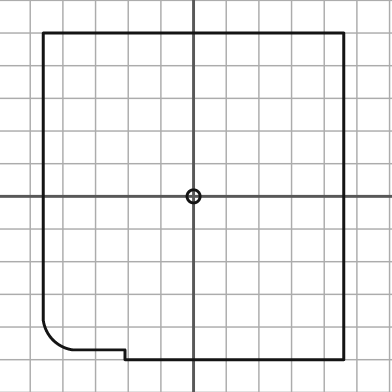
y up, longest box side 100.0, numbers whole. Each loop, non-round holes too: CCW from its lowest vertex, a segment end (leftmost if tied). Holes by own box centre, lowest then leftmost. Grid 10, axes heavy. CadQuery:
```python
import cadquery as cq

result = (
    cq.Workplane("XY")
    .moveTo(-21.0, -50.0)
    .lineTo(46.0, -50.0)
    .lineTo(46.0, 50.0)
    .lineTo(-46.0, 50.0)
    .lineTo(-46.0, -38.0)
    .threePointArc((-43.0, -44.0), (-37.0, -47.0))
    .lineTo(-21.0, -47.0)
    .close()
    .moveTo(0.0, 0.0)
    .circle(2.0)
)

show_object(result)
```